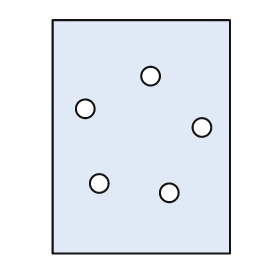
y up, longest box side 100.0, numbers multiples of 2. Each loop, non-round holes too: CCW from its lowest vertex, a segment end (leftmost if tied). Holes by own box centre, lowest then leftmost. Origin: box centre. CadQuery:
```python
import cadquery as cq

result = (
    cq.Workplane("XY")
    .moveTo(-38.0, -50.0)
    .lineTo(38.0, -50.0)
    .lineTo(38.0, 50.0)
    .lineTo(-38.0, 50.0)
    .close()
    .moveTo(12.0, -24.0)
    .circle(4.0)
    .moveTo(-18.0, -20.0)
    .circle(4.0)
    .moveTo(26.0, 4.0)
    .circle(4.0)
    .moveTo(-24.0, 12.0)
    .circle(4.0)
    .moveTo(4.0, 26.0)
    .circle(4.0)
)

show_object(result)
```